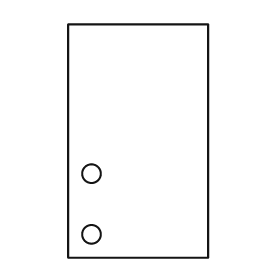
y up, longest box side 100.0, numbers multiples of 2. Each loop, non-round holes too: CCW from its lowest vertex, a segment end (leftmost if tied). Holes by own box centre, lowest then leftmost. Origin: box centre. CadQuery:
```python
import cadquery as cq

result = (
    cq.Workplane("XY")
    .moveTo(-30.0, -50.0)
    .lineTo(30.0, -50.0)
    .lineTo(30.0, 50.0)
    .lineTo(-30.0, 50.0)
    .close()
    .moveTo(-20.0, -40.0)
    .circle(4.0)
    .moveTo(-20.0, -14.0)
    .circle(4.0)
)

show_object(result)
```